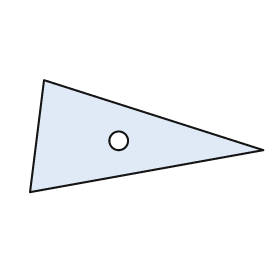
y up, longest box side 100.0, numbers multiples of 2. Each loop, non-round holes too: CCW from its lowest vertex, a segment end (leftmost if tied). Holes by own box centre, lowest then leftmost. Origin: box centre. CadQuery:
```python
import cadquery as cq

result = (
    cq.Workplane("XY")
    .moveTo(-50.0, -24.0)
    .lineTo(50.0, -6.0)
    .lineTo(-44.0, 24.0)
    .close()
    .moveTo(-12.0, -2.0)
    .circle(4.0)
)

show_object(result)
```